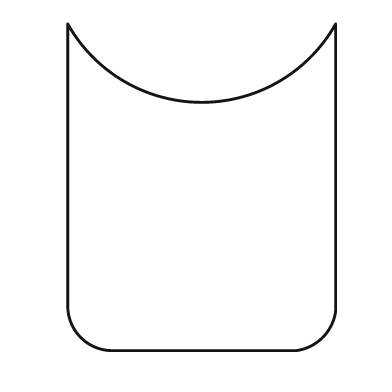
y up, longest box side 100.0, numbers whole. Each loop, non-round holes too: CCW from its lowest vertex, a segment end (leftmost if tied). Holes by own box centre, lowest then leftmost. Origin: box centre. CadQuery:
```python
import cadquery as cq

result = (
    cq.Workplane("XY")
    .moveTo(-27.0, -50.0)
    .lineTo(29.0, -50.0)
    .threePointArc((37.0, -46.0), (41.0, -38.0))
    .lineTo(41.0, 50.0)
    .threePointArc((0.0, 26.0), (-41.0, 50.0))
    .lineTo(-41.0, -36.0)
    .threePointArc((-37.0, -46.0), (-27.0, -50.0))
    .close()
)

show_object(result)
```